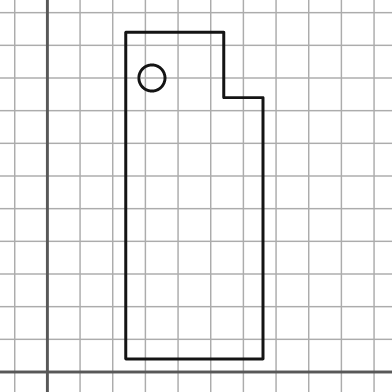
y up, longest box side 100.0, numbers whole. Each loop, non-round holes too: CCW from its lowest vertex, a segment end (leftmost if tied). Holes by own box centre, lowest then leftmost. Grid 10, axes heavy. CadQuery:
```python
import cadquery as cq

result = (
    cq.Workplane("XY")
    .moveTo(24.0, 4.0)
    .lineTo(66.0, 4.0)
    .lineTo(66.0, 84.0)
    .lineTo(54.0, 84.0)
    .lineTo(54.0, 104.0)
    .lineTo(24.0, 104.0)
    .close()
    .moveTo(32.0, 90.0)
    .circle(4.0)
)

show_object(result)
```